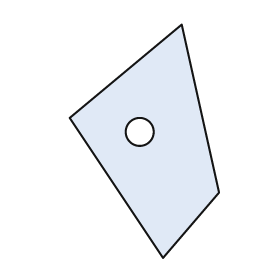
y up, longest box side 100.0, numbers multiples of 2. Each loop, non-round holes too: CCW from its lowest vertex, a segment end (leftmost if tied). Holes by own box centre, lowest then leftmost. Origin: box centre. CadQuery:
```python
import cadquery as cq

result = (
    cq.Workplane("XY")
    .moveTo(8.0, -50.0)
    .lineTo(32.0, -22.0)
    .lineTo(16.0, 50.0)
    .lineTo(-32.0, 10.0)
    .close()
    .moveTo(-2.0, 4.0)
    .circle(6.0)
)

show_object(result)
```